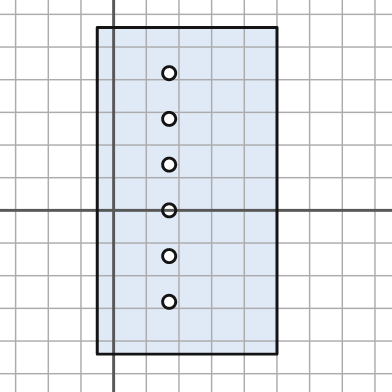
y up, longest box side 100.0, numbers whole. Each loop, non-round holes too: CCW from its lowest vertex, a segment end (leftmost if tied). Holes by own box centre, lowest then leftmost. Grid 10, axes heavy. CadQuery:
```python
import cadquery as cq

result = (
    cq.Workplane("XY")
    .moveTo(-5.0, -44.0)
    .lineTo(50.0, -44.0)
    .lineTo(50.0, 56.0)
    .lineTo(-5.0, 56.0)
    .close()
    .moveTo(17.0, -28.0)
    .circle(2.0)
    .moveTo(17.0, -14.0)
    .circle(2.0)
    .moveTo(17.0, 0.0)
    .circle(2.0)
    .moveTo(17.0, 14.0)
    .circle(2.0)
    .moveTo(17.0, 28.0)
    .circle(2.0)
    .moveTo(17.0, 42.0)
    .circle(2.0)
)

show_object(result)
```